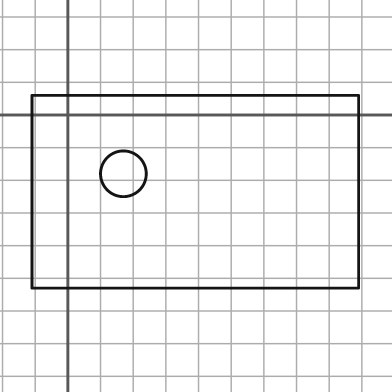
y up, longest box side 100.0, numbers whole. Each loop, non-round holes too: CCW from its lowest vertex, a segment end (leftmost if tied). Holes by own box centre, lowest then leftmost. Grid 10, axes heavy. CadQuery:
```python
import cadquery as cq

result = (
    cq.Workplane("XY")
    .moveTo(-11.0, -53.0)
    .lineTo(89.0, -53.0)
    .lineTo(89.0, 6.0)
    .lineTo(-11.0, 6.0)
    .close()
    .moveTo(17.0, -18.0)
    .circle(7.0)
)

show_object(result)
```